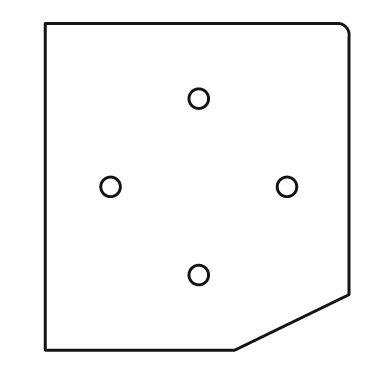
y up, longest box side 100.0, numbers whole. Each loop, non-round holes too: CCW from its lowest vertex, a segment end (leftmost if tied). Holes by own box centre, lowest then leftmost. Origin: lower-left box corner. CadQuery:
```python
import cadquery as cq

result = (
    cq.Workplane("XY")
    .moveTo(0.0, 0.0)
    .lineTo(58.0, 0.0)
    .lineTo(93.0, 17.0)
    .lineTo(93.0, 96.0)
    .threePointArc((92.0, 99.0), (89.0, 100.0))
    .lineTo(0.0, 100.0)
    .close()
    .moveTo(47.0, 23.0)
    .circle(3.0)
    .moveTo(20.0, 50.0)
    .circle(3.0)
    .moveTo(74.0, 50.0)
    .circle(3.0)
    .moveTo(47.0, 77.0)
    .circle(3.0)
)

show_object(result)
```